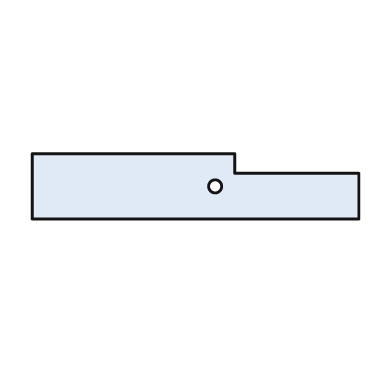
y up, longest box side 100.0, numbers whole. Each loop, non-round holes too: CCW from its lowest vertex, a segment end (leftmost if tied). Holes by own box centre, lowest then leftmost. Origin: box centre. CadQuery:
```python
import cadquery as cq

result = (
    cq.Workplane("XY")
    .moveTo(-50.0, -10.0)
    .lineTo(50.0, -10.0)
    .lineTo(50.0, 4.0)
    .lineTo(12.0, 4.0)
    .lineTo(12.0, 10.0)
    .lineTo(-50.0, 10.0)
    .close()
    .moveTo(6.0, 0.0)
    .circle(2.0)
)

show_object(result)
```